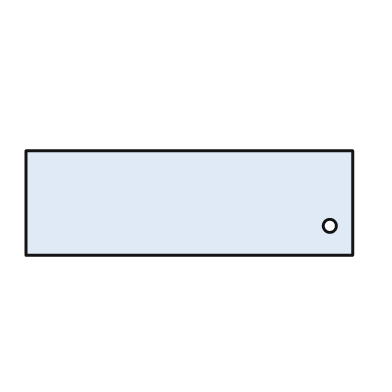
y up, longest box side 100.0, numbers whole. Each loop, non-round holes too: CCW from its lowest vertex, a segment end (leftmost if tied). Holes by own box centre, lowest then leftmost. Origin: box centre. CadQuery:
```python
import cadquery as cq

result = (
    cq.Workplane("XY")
    .moveTo(-50.0, -16.0)
    .lineTo(50.0, -16.0)
    .lineTo(50.0, 16.0)
    .lineTo(-50.0, 16.0)
    .close()
    .moveTo(43.0, -7.0)
    .circle(2.0)
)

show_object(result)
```